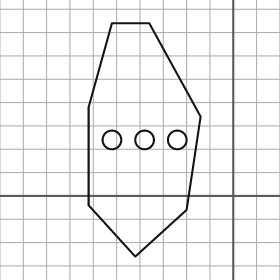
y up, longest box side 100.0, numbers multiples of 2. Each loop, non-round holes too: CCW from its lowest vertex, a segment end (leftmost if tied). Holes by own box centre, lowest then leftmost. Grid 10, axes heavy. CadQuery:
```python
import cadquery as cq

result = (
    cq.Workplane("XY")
    .moveTo(-42.0, -26.0)
    .lineTo(-20.0, -6.0)
    .lineTo(-14.0, 34.0)
    .lineTo(-36.0, 74.0)
    .lineTo(-52.0, 74.0)
    .lineTo(-62.0, 38.0)
    .lineTo(-62.0, -4.0)
    .close()
    .moveTo(-52.0, 24.0)
    .circle(4.0)
    .moveTo(-38.0, 24.0)
    .circle(4.0)
    .moveTo(-24.0, 24.0)
    .circle(4.0)
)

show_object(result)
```